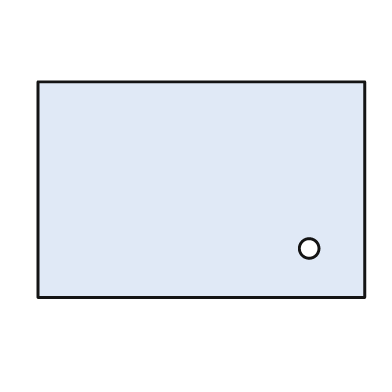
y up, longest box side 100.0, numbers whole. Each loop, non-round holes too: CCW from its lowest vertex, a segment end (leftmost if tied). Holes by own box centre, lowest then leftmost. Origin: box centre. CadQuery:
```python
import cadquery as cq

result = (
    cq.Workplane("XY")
    .moveTo(-50.0, -33.0)
    .lineTo(50.0, -33.0)
    .lineTo(50.0, 33.0)
    .lineTo(-50.0, 33.0)
    .close()
    .moveTo(33.0, -18.0)
    .circle(3.0)
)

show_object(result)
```